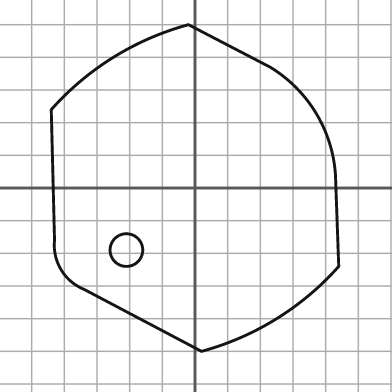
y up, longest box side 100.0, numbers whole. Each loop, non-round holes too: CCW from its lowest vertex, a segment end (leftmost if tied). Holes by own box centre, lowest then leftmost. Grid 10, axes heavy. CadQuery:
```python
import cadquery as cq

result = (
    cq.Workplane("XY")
    .moveTo(2.0, -50.0)
    .threePointArc((25.0, -40.0), (44.0, -24.0))
    .lineTo(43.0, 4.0)
    .threePointArc((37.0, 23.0), (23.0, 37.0))
    .lineTo(-2.0, 50.0)
    .threePointArc((-25.0, 40.0), (-44.0, 24.0))
    .lineTo(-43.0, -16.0)
    .threePointArc((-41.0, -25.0), (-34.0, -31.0))
    .close()
    .moveTo(-21.0, -19.0)
    .circle(5.0)
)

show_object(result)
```